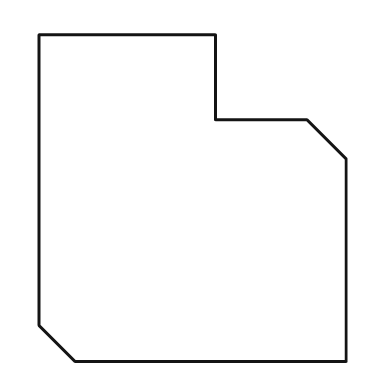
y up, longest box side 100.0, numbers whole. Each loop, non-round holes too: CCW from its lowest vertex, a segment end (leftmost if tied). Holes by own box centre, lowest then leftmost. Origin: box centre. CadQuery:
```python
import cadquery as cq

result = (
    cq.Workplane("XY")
    .moveTo(-36.0, -50.0)
    .lineTo(47.0, -50.0)
    .lineTo(47.0, 12.0)
    .lineTo(35.0, 24.0)
    .lineTo(7.0, 24.0)
    .lineTo(7.0, 50.0)
    .lineTo(-47.0, 50.0)
    .lineTo(-47.0, -39.0)
    .close()
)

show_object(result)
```